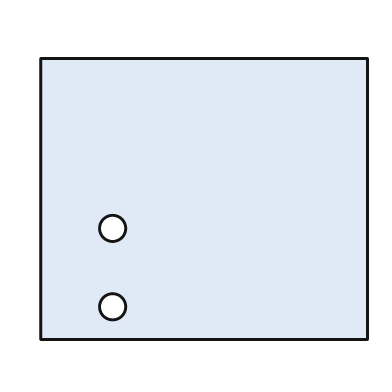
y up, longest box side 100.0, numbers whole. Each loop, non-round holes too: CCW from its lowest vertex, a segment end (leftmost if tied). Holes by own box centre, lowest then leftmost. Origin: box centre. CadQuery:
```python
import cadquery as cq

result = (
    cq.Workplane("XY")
    .moveTo(-50.0, -43.0)
    .lineTo(50.0, -43.0)
    .lineTo(50.0, 43.0)
    .lineTo(-50.0, 43.0)
    .close()
    .moveTo(-28.0, -33.0)
    .circle(4.0)
    .moveTo(-28.0, -9.0)
    .circle(4.0)
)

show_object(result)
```